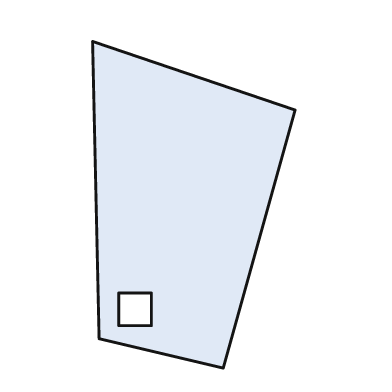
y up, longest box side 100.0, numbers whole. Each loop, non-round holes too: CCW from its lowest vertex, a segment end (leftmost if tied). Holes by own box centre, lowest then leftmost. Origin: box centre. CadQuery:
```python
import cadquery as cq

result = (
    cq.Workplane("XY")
    .moveTo(9.0, -50.0)
    .lineTo(31.0, 29.0)
    .lineTo(-31.0, 50.0)
    .lineTo(-29.0, -41.0)
    .close()
    .moveTo(-23.0, -37.0)
    .lineTo(-13.0, -37.0)
    .lineTo(-13.0, -27.0)
    .lineTo(-23.0, -27.0)
    .close()
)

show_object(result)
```